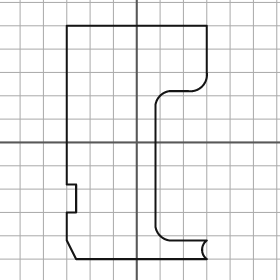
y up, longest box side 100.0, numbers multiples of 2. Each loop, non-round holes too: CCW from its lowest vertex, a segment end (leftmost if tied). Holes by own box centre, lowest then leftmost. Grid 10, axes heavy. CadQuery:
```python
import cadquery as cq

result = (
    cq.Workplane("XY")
    .moveTo(-26.0, -50.0)
    .lineTo(30.0, -50.0)
    .threePointArc((28.0, -46.0), (30.0, -42.0))
    .lineTo(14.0, -42.0)
    .threePointArc((10.0, -40.0), (8.0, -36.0))
    .lineTo(8.0, 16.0)
    .threePointArc((10.0, 20.0), (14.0, 22.0))
    .lineTo(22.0, 22.0)
    .threePointArc((28.0, 24.0), (30.0, 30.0))
    .lineTo(30.0, 50.0)
    .lineTo(-30.0, 50.0)
    .lineTo(-30.0, -18.0)
    .lineTo(-26.0, -18.0)
    .lineTo(-26.0, -30.0)
    .lineTo(-30.0, -30.0)
    .lineTo(-30.0, -42.0)
    .close()
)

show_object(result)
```